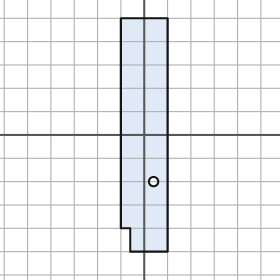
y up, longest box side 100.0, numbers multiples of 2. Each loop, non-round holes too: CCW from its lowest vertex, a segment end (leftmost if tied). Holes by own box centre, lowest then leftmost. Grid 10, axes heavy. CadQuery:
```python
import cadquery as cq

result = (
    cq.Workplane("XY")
    .moveTo(-6.0, -50.0)
    .lineTo(10.0, -50.0)
    .lineTo(10.0, 50.0)
    .lineTo(-10.0, 50.0)
    .lineTo(-10.0, -40.0)
    .lineTo(-6.0, -40.0)
    .close()
    .moveTo(4.0, -20.0)
    .circle(2.0)
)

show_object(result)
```